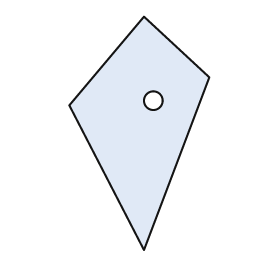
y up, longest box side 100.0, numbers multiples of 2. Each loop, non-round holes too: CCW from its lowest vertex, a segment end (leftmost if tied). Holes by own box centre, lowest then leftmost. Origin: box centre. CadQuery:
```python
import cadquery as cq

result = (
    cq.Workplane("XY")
    .moveTo(2.0, -50.0)
    .lineTo(30.0, 24.0)
    .lineTo(2.0, 50.0)
    .lineTo(-30.0, 12.0)
    .close()
    .moveTo(6.0, 14.0)
    .circle(4.0)
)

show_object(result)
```